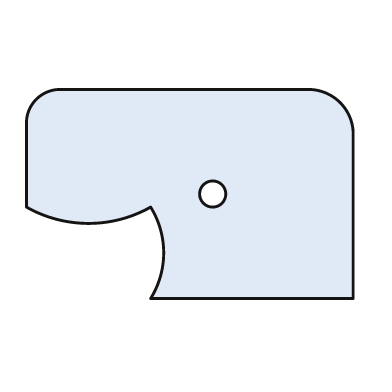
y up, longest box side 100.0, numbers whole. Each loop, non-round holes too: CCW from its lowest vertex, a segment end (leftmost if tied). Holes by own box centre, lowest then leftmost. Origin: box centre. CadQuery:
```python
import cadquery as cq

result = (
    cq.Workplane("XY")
    .moveTo(-12.0, -32.0)
    .lineTo(50.0, -32.0)
    .lineTo(50.0, 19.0)
    .threePointArc((46.0, 28.0), (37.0, 32.0))
    .lineTo(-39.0, 32.0)
    .threePointArc((-47.0, 29.0), (-50.0, 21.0))
    .lineTo(-50.0, -4.0)
    .threePointArc((-31.0, -9.0), (-12.0, -4.0))
    .threePointArc((-8.0, -18.0), (-12.0, -32.0))
    .close()
    .moveTo(7.0, 0.0)
    .circle(4.0)
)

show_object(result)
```